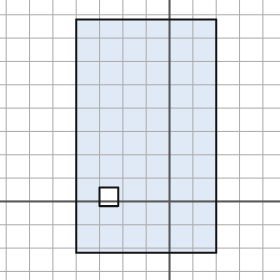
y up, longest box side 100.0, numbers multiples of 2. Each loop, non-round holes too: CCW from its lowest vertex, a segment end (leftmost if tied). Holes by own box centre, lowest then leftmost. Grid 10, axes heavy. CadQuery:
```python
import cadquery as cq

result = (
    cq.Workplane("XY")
    .moveTo(-40.0, -22.0)
    .lineTo(20.0, -22.0)
    .lineTo(20.0, 78.0)
    .lineTo(-40.0, 78.0)
    .close()
    .moveTo(-30.0, -2.0)
    .lineTo(-22.0, -2.0)
    .lineTo(-22.0, 6.0)
    .lineTo(-30.0, 6.0)
    .close()
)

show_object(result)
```